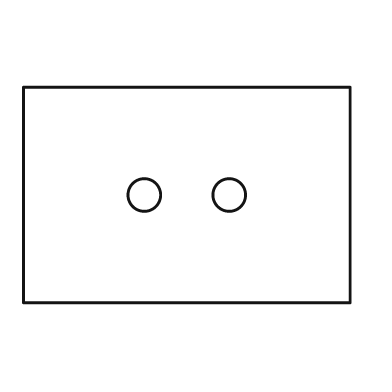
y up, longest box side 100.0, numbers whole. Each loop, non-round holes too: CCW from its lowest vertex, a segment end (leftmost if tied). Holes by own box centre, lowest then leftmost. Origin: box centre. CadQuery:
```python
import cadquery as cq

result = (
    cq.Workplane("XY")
    .moveTo(-50.0, -33.0)
    .lineTo(50.0, -33.0)
    .lineTo(50.0, 33.0)
    .lineTo(-50.0, 33.0)
    .close()
    .moveTo(-13.0, 0.0)
    .circle(5.0)
    .moveTo(13.0, 0.0)
    .circle(5.0)
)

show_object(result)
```